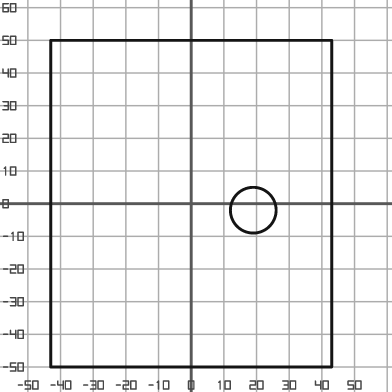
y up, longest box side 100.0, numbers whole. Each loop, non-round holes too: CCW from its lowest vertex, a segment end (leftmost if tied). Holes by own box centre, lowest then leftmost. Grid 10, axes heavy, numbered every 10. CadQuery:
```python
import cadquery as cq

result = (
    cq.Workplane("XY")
    .moveTo(-43.0, -50.0)
    .lineTo(43.0, -50.0)
    .lineTo(43.0, 50.0)
    .lineTo(-43.0, 50.0)
    .close()
    .moveTo(19.0, -2.0)
    .circle(7.0)
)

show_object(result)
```